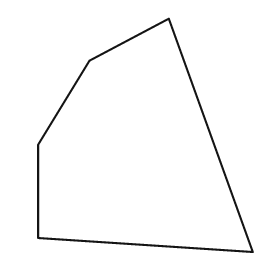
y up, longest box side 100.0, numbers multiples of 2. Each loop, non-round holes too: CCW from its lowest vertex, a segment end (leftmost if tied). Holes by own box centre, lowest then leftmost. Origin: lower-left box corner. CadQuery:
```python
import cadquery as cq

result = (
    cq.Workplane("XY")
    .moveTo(92.0, 0.0)
    .lineTo(56.0, 100.0)
    .lineTo(22.0, 82.0)
    .lineTo(0.0, 46.0)
    .lineTo(0.0, 6.0)
    .close()
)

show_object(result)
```